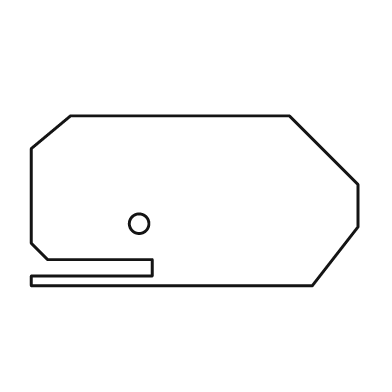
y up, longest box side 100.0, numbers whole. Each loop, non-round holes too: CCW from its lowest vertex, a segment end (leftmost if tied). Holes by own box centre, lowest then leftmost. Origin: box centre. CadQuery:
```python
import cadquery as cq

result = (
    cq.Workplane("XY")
    .moveTo(-50.0, -26.0)
    .lineTo(36.0, -26.0)
    .lineTo(50.0, -8.0)
    .lineTo(50.0, 5.0)
    .lineTo(29.0, 26.0)
    .lineTo(-38.0, 26.0)
    .lineTo(-50.0, 16.0)
    .lineTo(-50.0, -13.0)
    .lineTo(-45.0, -18.0)
    .lineTo(-13.0, -18.0)
    .lineTo(-13.0, -23.0)
    .lineTo(-50.0, -23.0)
    .close()
    .moveTo(-17.0, -7.0)
    .circle(3.0)
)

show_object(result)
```